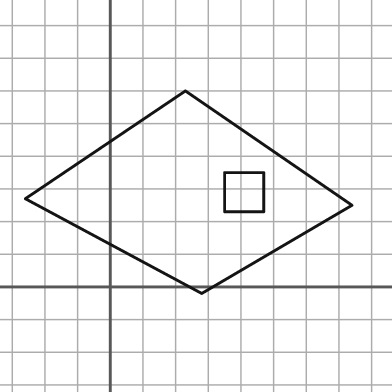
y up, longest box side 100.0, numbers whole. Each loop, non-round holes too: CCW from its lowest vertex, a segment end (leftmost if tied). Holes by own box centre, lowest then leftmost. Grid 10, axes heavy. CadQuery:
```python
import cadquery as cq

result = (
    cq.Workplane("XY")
    .moveTo(28.0, -2.0)
    .lineTo(74.0, 25.0)
    .lineTo(23.0, 60.0)
    .lineTo(-26.0, 27.0)
    .close()
    .moveTo(35.0, 23.0)
    .lineTo(47.0, 23.0)
    .lineTo(47.0, 35.0)
    .lineTo(35.0, 35.0)
    .close()
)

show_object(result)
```